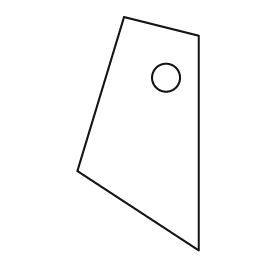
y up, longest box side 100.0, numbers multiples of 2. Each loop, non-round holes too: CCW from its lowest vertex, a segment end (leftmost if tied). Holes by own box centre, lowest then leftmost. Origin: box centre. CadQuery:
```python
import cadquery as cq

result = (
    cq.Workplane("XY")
    .moveTo(26.0, -50.0)
    .lineTo(26.0, 42.0)
    .lineTo(-6.0, 50.0)
    .lineTo(-26.0, -16.0)
    .close()
    .moveTo(12.0, 24.0)
    .circle(6.0)
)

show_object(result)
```